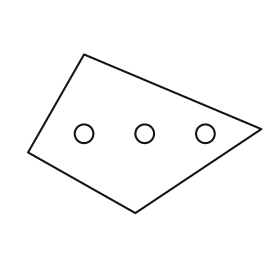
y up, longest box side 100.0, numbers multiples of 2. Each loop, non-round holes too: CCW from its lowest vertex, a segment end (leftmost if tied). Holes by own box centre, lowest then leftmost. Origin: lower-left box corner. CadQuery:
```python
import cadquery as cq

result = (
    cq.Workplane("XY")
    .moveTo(46.0, 0.0)
    .lineTo(100.0, 36.0)
    .lineTo(24.0, 68.0)
    .lineTo(0.0, 26.0)
    .close()
    .moveTo(24.0, 34.0)
    .circle(4.0)
    .moveTo(50.0, 34.0)
    .circle(4.0)
    .moveTo(76.0, 34.0)
    .circle(4.0)
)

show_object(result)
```